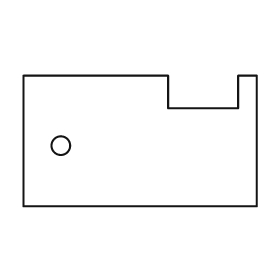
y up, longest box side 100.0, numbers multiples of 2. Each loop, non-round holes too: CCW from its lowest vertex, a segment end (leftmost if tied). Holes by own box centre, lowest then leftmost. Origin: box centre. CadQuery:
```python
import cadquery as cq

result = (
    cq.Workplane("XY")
    .moveTo(-50.0, -28.0)
    .lineTo(50.0, -28.0)
    .lineTo(50.0, 28.0)
    .lineTo(42.0, 28.0)
    .lineTo(42.0, 14.0)
    .lineTo(12.0, 14.0)
    .lineTo(12.0, 28.0)
    .lineTo(-50.0, 28.0)
    .close()
    .moveTo(-34.0, -2.0)
    .circle(4.0)
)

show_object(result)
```